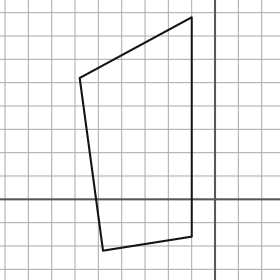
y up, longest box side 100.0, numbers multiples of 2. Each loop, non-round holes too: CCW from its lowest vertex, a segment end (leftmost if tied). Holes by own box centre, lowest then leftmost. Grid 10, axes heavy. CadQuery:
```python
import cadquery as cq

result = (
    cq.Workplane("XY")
    .moveTo(-48.0, -22.0)
    .lineTo(-10.0, -16.0)
    .lineTo(-10.0, 78.0)
    .lineTo(-58.0, 52.0)
    .close()
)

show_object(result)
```